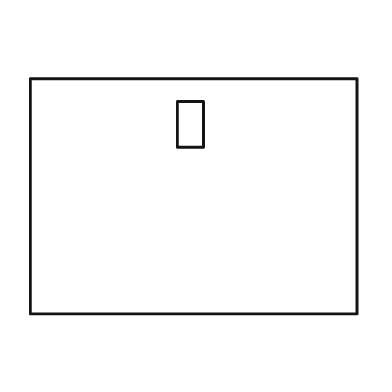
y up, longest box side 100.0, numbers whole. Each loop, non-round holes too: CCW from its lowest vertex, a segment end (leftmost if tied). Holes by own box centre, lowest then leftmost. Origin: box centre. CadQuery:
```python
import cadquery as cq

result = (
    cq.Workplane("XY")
    .moveTo(-50.0, -36.0)
    .lineTo(50.0, -36.0)
    .lineTo(50.0, 36.0)
    .lineTo(-50.0, 36.0)
    .close()
    .moveTo(-5.0, 15.0)
    .lineTo(3.0, 15.0)
    .lineTo(3.0, 29.0)
    .lineTo(-5.0, 29.0)
    .close()
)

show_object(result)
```